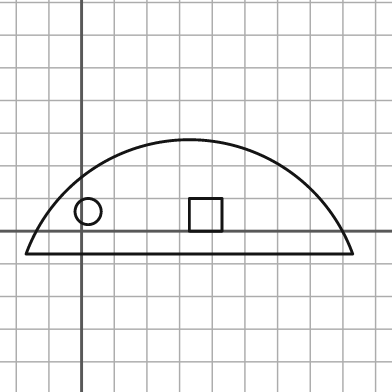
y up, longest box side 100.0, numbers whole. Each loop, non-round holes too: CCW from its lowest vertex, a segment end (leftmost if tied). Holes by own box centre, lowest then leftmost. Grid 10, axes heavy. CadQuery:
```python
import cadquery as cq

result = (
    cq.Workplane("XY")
    .moveTo(-17.0, -7.0)
    .lineTo(83.0, -7.0)
    .threePointArc((33.0, 28.0), (-17.0, -7.0))
    .close()
    .moveTo(33.0, 0.0)
    .lineTo(43.0, 0.0)
    .lineTo(43.0, 10.0)
    .lineTo(33.0, 10.0)
    .close()
    .moveTo(2.0, 6.0)
    .circle(4.0)
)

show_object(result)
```